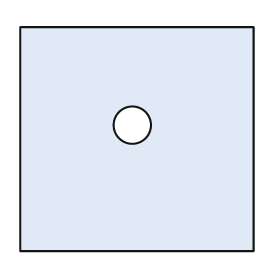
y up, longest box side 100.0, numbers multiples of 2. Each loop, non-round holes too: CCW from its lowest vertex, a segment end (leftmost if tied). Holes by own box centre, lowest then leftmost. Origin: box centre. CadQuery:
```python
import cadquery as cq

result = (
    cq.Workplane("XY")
    .moveTo(-50.0, -48.0)
    .lineTo(50.0, -48.0)
    .lineTo(50.0, 48.0)
    .lineTo(-50.0, 48.0)
    .close()
    .moveTo(-2.0, 6.0)
    .circle(8.0)
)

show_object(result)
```